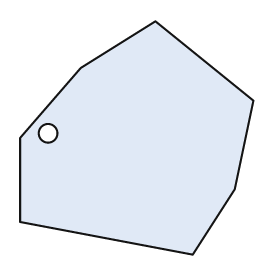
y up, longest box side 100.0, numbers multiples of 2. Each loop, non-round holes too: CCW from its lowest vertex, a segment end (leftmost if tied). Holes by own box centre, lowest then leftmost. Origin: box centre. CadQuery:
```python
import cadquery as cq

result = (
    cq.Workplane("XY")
    .moveTo(24.0, -50.0)
    .lineTo(42.0, -22.0)
    .lineTo(50.0, 16.0)
    .lineTo(8.0, 50.0)
    .lineTo(-24.0, 30.0)
    .lineTo(-50.0, 0.0)
    .lineTo(-50.0, -36.0)
    .close()
    .moveTo(-38.0, 2.0)
    .circle(4.0)
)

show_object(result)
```